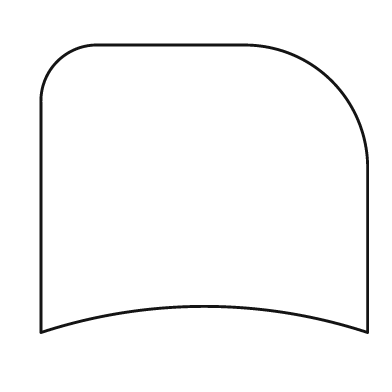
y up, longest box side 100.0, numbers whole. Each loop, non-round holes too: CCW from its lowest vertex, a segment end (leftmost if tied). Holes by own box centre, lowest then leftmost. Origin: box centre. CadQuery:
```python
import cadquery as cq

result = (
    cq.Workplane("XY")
    .moveTo(-50.0, -44.0)
    .threePointArc((0.0, -36.0), (50.0, -44.0))
    .lineTo(50.0, 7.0)
    .threePointArc((39.0, 33.0), (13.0, 44.0))
    .lineTo(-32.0, 44.0)
    .threePointArc((-45.0, 39.0), (-50.0, 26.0))
    .close()
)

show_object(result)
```